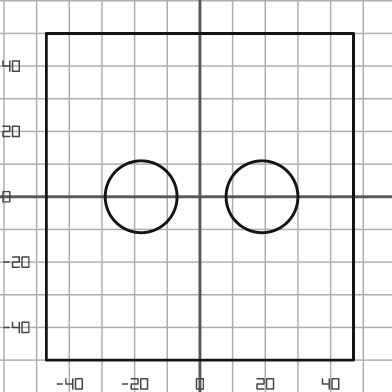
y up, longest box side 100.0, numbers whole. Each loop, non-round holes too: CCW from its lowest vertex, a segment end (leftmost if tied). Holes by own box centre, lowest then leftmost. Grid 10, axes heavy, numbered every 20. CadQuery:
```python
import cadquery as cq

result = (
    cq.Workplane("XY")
    .moveTo(-47.0, -50.0)
    .lineTo(47.0, -50.0)
    .lineTo(47.0, 50.0)
    .lineTo(-47.0, 50.0)
    .close()
    .moveTo(-18.0, 0.0)
    .circle(11.0)
    .moveTo(19.0, 0.0)
    .circle(11.0)
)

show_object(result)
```